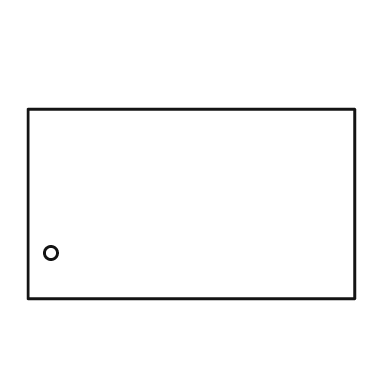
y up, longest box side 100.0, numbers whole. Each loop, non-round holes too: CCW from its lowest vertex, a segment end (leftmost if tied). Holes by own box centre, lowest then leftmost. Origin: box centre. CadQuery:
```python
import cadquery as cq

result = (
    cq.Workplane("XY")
    .moveTo(-50.0, -29.0)
    .lineTo(50.0, -29.0)
    .lineTo(50.0, 29.0)
    .lineTo(-50.0, 29.0)
    .close()
    .moveTo(-43.0, -15.0)
    .circle(2.0)
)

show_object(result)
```